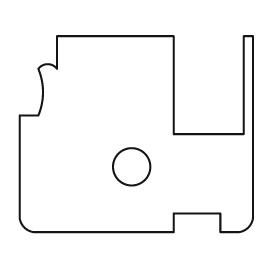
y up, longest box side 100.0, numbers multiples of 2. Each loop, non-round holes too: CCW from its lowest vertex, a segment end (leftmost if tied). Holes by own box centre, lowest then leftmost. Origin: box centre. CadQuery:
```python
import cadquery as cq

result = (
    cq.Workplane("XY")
    .moveTo(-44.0, -42.0)
    .lineTo(16.0, -42.0)
    .lineTo(16.0, -34.0)
    .lineTo(36.0, -34.0)
    .lineTo(36.0, -42.0)
    .lineTo(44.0, -42.0)
    .threePointArc((48.0, -40.0), (50.0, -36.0))
    .lineTo(50.0, 42.0)
    .lineTo(46.0, 42.0)
    .lineTo(46.0, 0.0)
    .lineTo(16.0, 0.0)
    .lineTo(16.0, 42.0)
    .lineTo(-34.0, 42.0)
    .lineTo(-34.0, 28.0)
    .threePointArc((-38.0, 30.0), (-42.0, 28.0))
    .threePointArc((-40.0, 18.0), (-42.0, 8.0))
    .lineTo(-50.0, 8.0)
    .lineTo(-50.0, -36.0)
    .threePointArc((-48.0, -40.0), (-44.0, -42.0))
    .close()
    .moveTo(-2.0, -14.0)
    .circle(8.0)
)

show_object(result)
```